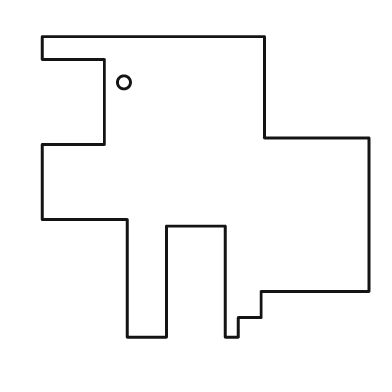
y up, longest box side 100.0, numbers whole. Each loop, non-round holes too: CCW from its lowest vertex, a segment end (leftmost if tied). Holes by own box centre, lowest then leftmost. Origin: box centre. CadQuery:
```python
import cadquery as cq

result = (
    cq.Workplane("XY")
    .moveTo(-24.0, -46.0)
    .lineTo(-12.0, -46.0)
    .lineTo(-12.0, -12.0)
    .lineTo(6.0, -12.0)
    .lineTo(6.0, -46.0)
    .lineTo(10.0, -46.0)
    .lineTo(10.0, -40.0)
    .lineTo(17.0, -40.0)
    .lineTo(17.0, -32.0)
    .lineTo(50.0, -32.0)
    .lineTo(50.0, 15.0)
    .lineTo(18.0, 15.0)
    .lineTo(18.0, 46.0)
    .lineTo(-50.0, 46.0)
    .lineTo(-50.0, 39.0)
    .lineTo(-31.0, 39.0)
    .lineTo(-31.0, 13.0)
    .lineTo(-50.0, 13.0)
    .lineTo(-50.0, -10.0)
    .lineTo(-24.0, -10.0)
    .close()
    .moveTo(-25.0, 32.0)
    .circle(2.0)
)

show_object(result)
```